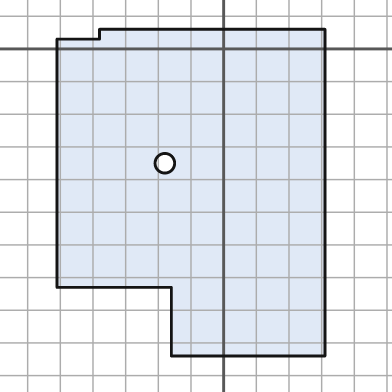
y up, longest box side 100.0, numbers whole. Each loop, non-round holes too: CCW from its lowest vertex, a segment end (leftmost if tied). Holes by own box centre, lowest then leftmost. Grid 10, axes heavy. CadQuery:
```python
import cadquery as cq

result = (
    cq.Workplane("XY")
    .moveTo(-16.0, -94.0)
    .lineTo(31.0, -94.0)
    .lineTo(31.0, 6.0)
    .lineTo(-38.0, 6.0)
    .lineTo(-38.0, 3.0)
    .lineTo(-51.0, 3.0)
    .lineTo(-51.0, -73.0)
    .lineTo(-16.0, -73.0)
    .close()
    .moveTo(-18.0, -35.0)
    .circle(3.0)
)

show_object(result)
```